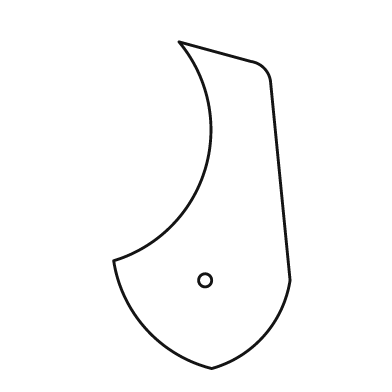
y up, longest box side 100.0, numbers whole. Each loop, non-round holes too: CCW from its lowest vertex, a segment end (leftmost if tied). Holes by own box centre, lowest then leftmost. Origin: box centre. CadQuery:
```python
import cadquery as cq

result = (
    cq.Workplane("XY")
    .moveTo(3.0, -50.0)
    .threePointArc((19.0, -40.0), (27.0, -23.0))
    .lineTo(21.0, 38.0)
    .threePointArc((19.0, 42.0), (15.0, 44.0))
    .lineTo(-7.0, 50.0)
    .threePointArc((1.0, 11.0), (-27.0, -17.0))
    .threePointArc((-17.0, -38.0), (3.0, -50.0))
    .close()
    .moveTo(1.0, -23.0)
    .circle(2.0)
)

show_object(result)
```